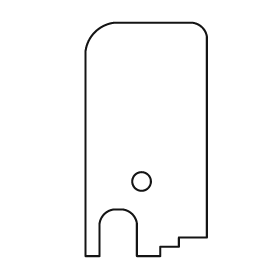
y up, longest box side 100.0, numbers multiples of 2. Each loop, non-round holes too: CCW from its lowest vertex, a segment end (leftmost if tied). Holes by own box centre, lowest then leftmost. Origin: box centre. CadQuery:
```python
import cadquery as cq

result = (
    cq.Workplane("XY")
    .moveTo(-26.0, -50.0)
    .lineTo(-20.0, -50.0)
    .lineTo(-20.0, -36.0)
    .threePointArc((-18.0, -32.0), (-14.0, -30.0))
    .lineTo(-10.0, -30.0)
    .threePointArc((-6.0, -32.0), (-4.0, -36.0))
    .lineTo(-4.0, -50.0)
    .lineTo(6.0, -50.0)
    .lineTo(6.0, -46.0)
    .lineTo(14.0, -46.0)
    .lineTo(14.0, -42.0)
    .lineTo(26.0, -42.0)
    .lineTo(26.0, 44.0)
    .threePointArc((24.0, 48.0), (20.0, 50.0))
    .lineTo(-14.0, 50.0)
    .threePointArc((-22.0, 46.0), (-26.0, 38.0))
    .close()
    .moveTo(-2.0, -18.0)
    .circle(4.0)
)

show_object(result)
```